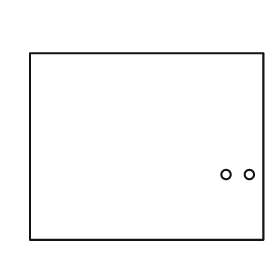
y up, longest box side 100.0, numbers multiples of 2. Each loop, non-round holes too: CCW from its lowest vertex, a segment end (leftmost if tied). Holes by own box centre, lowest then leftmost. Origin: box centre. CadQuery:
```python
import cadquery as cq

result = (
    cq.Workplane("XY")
    .moveTo(-50.0, -40.0)
    .lineTo(50.0, -40.0)
    .lineTo(50.0, 40.0)
    .lineTo(-50.0, 40.0)
    .close()
    .moveTo(34.0, -12.0)
    .circle(2.0)
    .moveTo(44.0, -12.0)
    .circle(2.0)
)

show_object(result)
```